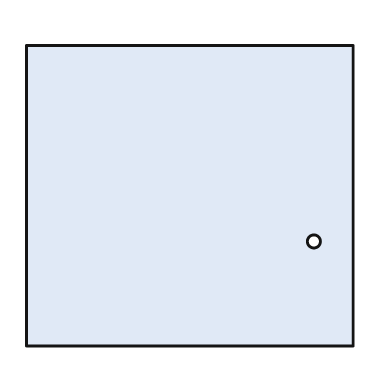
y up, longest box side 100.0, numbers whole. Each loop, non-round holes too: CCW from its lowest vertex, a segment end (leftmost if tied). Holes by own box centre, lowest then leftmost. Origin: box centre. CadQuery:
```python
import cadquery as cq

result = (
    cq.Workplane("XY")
    .moveTo(-50.0, -46.0)
    .lineTo(50.0, -46.0)
    .lineTo(50.0, 46.0)
    .lineTo(-50.0, 46.0)
    .close()
    .moveTo(38.0, -14.0)
    .circle(2.0)
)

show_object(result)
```